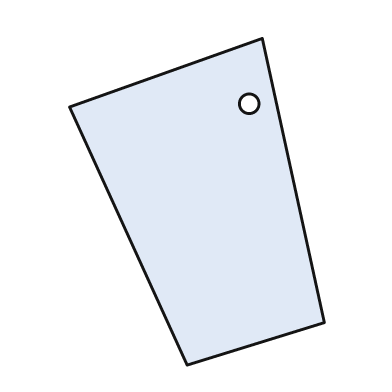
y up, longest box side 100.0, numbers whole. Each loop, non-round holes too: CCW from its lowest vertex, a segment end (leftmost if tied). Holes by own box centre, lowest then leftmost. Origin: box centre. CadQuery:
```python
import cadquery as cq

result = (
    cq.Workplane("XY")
    .moveTo(-3.0, -50.0)
    .lineTo(39.0, -37.0)
    .lineTo(20.0, 50.0)
    .lineTo(-39.0, 29.0)
    .close()
    .moveTo(16.0, 30.0)
    .circle(3.0)
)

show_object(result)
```